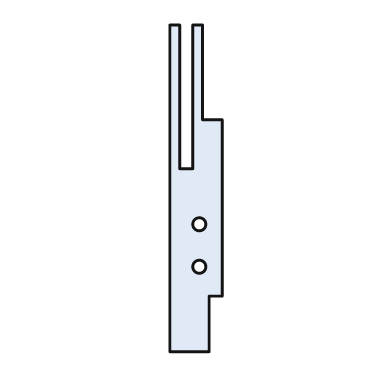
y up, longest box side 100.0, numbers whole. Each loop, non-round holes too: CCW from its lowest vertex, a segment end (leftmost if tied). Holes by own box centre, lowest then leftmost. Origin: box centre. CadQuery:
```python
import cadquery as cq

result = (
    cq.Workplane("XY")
    .moveTo(-8.0, -50.0)
    .lineTo(4.0, -50.0)
    .lineTo(4.0, -33.0)
    .lineTo(8.0, -33.0)
    .lineTo(8.0, 21.0)
    .lineTo(2.0, 21.0)
    .lineTo(2.0, 50.0)
    .lineTo(-1.0, 50.0)
    .lineTo(-1.0, 6.0)
    .lineTo(-5.0, 6.0)
    .lineTo(-5.0, 50.0)
    .lineTo(-8.0, 50.0)
    .close()
    .moveTo(1.0, -24.0)
    .circle(2.0)
    .moveTo(1.0, -11.0)
    .circle(2.0)
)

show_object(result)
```